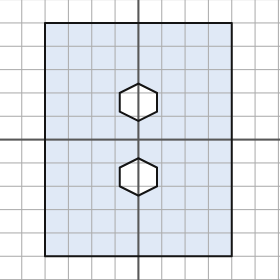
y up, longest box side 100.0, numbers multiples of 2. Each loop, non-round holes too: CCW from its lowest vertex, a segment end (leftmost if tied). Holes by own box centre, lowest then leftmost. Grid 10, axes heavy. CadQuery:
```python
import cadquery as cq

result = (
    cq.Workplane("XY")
    .moveTo(-40.0, -50.0)
    .lineTo(40.0, -50.0)
    .lineTo(40.0, 50.0)
    .lineTo(-40.0, 50.0)
    .close()
    .moveTo(0.0, -24.0)
    .lineTo(8.0, -20.0)
    .lineTo(8.0, -12.0)
    .lineTo(0.0, -8.0)
    .lineTo(-8.0, -12.0)
    .lineTo(-8.0, -20.0)
    .close()
    .moveTo(0.0, 8.0)
    .lineTo(8.0, 12.0)
    .lineTo(8.0, 20.0)
    .lineTo(0.0, 24.0)
    .lineTo(-8.0, 20.0)
    .lineTo(-8.0, 12.0)
    .close()
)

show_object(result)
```